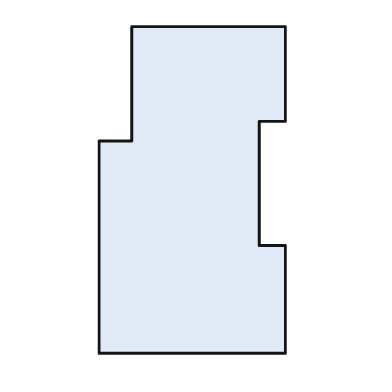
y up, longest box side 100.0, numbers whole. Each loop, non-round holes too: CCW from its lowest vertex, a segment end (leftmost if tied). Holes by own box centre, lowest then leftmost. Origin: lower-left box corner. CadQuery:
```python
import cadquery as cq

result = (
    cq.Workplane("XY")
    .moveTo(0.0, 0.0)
    .lineTo(57.0, 0.0)
    .lineTo(57.0, 33.0)
    .lineTo(49.0, 33.0)
    .lineTo(49.0, 71.0)
    .lineTo(57.0, 71.0)
    .lineTo(57.0, 100.0)
    .lineTo(10.0, 100.0)
    .lineTo(10.0, 65.0)
    .lineTo(0.0, 65.0)
    .close()
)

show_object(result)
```